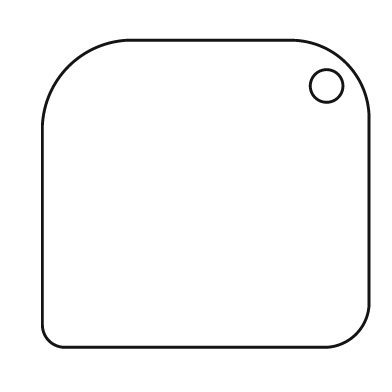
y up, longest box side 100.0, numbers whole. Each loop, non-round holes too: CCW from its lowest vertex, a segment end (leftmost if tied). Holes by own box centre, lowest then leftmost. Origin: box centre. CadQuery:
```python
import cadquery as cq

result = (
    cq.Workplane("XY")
    .moveTo(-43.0, -47.0)
    .lineTo(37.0, -47.0)
    .threePointArc((46.0, -43.0), (50.0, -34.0))
    .lineTo(50.0, 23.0)
    .threePointArc((43.0, 40.0), (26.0, 47.0))
    .lineTo(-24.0, 47.0)
    .threePointArc((-42.0, 39.0), (-50.0, 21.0))
    .lineTo(-50.0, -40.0)
    .threePointArc((-48.0, -45.0), (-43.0, -47.0))
    .close()
    .moveTo(37.0, 33.0)
    .circle(5.0)
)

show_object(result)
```